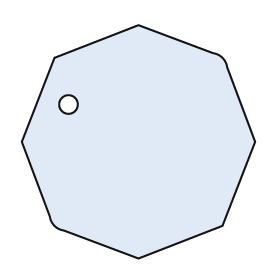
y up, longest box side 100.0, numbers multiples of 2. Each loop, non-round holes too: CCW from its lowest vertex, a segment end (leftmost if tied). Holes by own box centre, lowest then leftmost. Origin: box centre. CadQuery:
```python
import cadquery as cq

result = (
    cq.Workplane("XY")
    .moveTo(0.0, -50.0)
    .lineTo(36.0, -36.0)
    .lineTo(50.0, 0.0)
    .lineTo(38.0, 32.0)
    .threePointArc((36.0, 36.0), (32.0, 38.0))
    .lineTo(0.0, 50.0)
    .lineTo(-36.0, 36.0)
    .lineTo(-50.0, 0.0)
    .lineTo(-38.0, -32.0)
    .threePointArc((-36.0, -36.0), (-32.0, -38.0))
    .close()
    .moveTo(-30.0, 16.0)
    .circle(4.0)
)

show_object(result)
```